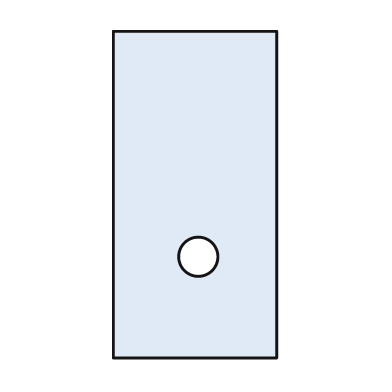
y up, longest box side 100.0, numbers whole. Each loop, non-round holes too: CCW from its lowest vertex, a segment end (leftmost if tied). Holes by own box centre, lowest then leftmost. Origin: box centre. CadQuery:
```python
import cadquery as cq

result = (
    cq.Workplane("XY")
    .moveTo(-25.0, -50.0)
    .lineTo(25.0, -50.0)
    .lineTo(25.0, 50.0)
    .lineTo(-25.0, 50.0)
    .close()
    .moveTo(1.0, -19.0)
    .circle(6.0)
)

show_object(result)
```